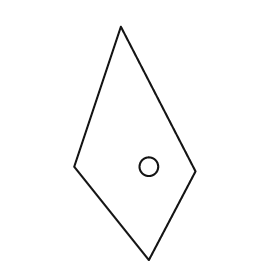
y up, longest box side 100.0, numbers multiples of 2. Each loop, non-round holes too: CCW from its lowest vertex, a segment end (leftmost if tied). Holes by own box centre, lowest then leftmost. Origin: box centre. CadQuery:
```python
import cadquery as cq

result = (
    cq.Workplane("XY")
    .moveTo(6.0, -50.0)
    .lineTo(26.0, -12.0)
    .lineTo(-6.0, 50.0)
    .lineTo(-26.0, -10.0)
    .close()
    .moveTo(6.0, -10.0)
    .circle(4.0)
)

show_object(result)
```